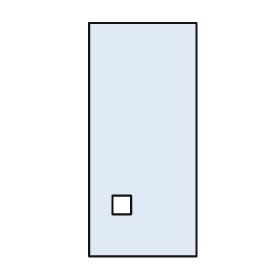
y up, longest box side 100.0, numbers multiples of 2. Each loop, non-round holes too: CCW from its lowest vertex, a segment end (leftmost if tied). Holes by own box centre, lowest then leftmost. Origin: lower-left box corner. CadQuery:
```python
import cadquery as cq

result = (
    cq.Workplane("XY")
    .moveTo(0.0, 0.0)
    .lineTo(46.0, 0.0)
    .lineTo(46.0, 100.0)
    .lineTo(0.0, 100.0)
    .close()
    .moveTo(10.0, 18.0)
    .lineTo(18.0, 18.0)
    .lineTo(18.0, 26.0)
    .lineTo(10.0, 26.0)
    .close()
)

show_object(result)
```